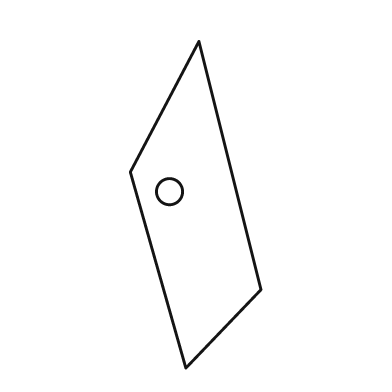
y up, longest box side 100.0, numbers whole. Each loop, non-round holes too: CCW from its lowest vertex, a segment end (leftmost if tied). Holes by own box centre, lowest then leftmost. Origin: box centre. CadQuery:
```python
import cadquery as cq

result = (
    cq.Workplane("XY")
    .moveTo(-3.0, -50.0)
    .lineTo(20.0, -26.0)
    .lineTo(1.0, 50.0)
    .lineTo(-20.0, 10.0)
    .close()
    .moveTo(-8.0, 4.0)
    .circle(4.0)
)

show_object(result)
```